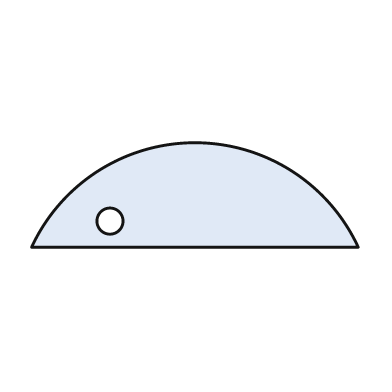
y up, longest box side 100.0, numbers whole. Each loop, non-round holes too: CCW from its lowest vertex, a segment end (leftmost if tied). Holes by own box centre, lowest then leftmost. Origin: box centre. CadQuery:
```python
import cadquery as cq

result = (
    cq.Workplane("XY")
    .moveTo(-50.0, -16.0)
    .lineTo(50.0, -16.0)
    .threePointArc((0.0, 16.0), (-50.0, -16.0))
    .close()
    .moveTo(-26.0, -8.0)
    .circle(4.0)
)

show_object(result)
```